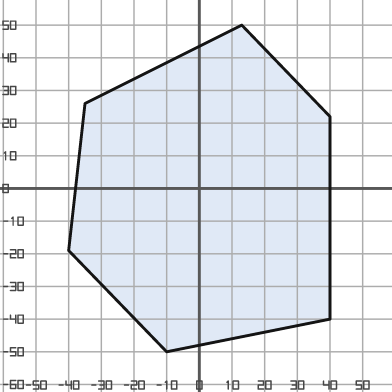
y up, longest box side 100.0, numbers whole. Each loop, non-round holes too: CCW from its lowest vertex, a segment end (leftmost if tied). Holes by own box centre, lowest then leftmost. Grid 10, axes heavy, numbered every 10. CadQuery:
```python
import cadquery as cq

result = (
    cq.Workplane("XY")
    .moveTo(-10.0, -50.0)
    .lineTo(40.0, -40.0)
    .lineTo(40.0, 22.0)
    .lineTo(13.0, 50.0)
    .lineTo(-35.0, 26.0)
    .lineTo(-40.0, -19.0)
    .close()
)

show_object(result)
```